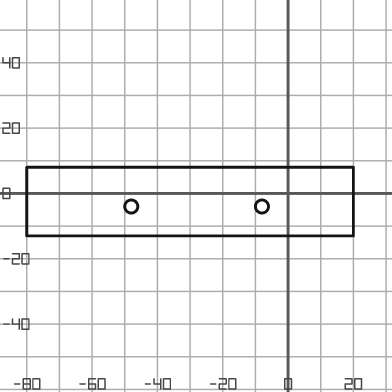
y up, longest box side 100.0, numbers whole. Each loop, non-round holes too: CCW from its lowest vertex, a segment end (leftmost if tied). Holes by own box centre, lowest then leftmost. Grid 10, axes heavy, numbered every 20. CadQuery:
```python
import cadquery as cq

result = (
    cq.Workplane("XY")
    .moveTo(-80.0, -13.0)
    .lineTo(20.0, -13.0)
    .lineTo(20.0, 8.0)
    .lineTo(-80.0, 8.0)
    .close()
    .moveTo(-48.0, -4.0)
    .circle(2.0)
    .moveTo(-8.0, -4.0)
    .circle(2.0)
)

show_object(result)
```